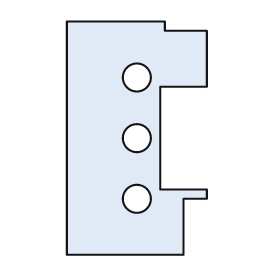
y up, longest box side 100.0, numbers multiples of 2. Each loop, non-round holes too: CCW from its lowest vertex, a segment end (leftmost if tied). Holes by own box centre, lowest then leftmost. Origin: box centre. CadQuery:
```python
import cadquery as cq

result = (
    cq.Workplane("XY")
    .moveTo(-30.0, -50.0)
    .lineTo(20.0, -50.0)
    .lineTo(20.0, -26.0)
    .lineTo(30.0, -26.0)
    .lineTo(30.0, -22.0)
    .lineTo(10.0, -22.0)
    .lineTo(10.0, 22.0)
    .lineTo(30.0, 22.0)
    .lineTo(30.0, 46.0)
    .lineTo(12.0, 46.0)
    .lineTo(12.0, 50.0)
    .lineTo(-30.0, 50.0)
    .close()
    .moveTo(0.0, -26.0)
    .circle(6.0)
    .moveTo(0.0, 0.0)
    .circle(6.0)
    .moveTo(0.0, 26.0)
    .circle(6.0)
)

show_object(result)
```